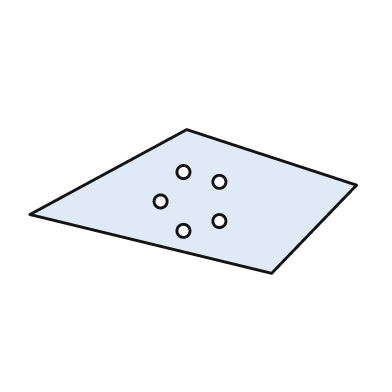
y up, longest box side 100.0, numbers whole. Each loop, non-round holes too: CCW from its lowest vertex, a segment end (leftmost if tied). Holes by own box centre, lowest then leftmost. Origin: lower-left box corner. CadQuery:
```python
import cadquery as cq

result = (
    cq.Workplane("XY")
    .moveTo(74.0, 0.0)
    .lineTo(100.0, 27.0)
    .lineTo(48.0, 44.0)
    .lineTo(0.0, 18.0)
    .close()
    .moveTo(47.0, 13.0)
    .circle(2.0)
    .moveTo(58.0, 16.0)
    .circle(2.0)
    .moveTo(40.0, 22.0)
    .circle(2.0)
    .moveTo(58.0, 28.0)
    .circle(2.0)
    .moveTo(47.0, 31.0)
    .circle(2.0)
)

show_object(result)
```